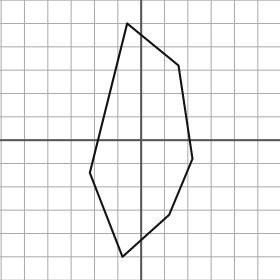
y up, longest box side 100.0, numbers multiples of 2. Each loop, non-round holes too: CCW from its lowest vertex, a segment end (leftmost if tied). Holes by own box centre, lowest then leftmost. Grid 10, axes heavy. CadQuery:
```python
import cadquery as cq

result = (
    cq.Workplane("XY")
    .moveTo(-8.0, -50.0)
    .lineTo(12.0, -32.0)
    .lineTo(22.0, -8.0)
    .lineTo(16.0, 32.0)
    .lineTo(-6.0, 50.0)
    .lineTo(-22.0, -14.0)
    .close()
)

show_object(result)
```